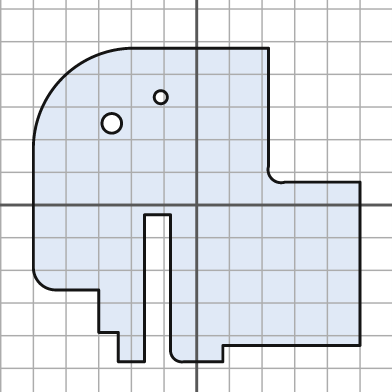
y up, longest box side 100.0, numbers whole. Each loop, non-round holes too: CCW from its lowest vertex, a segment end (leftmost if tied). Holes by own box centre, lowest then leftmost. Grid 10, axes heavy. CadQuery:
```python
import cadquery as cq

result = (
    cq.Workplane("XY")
    .moveTo(-24.0, -48.0)
    .lineTo(-16.0, -48.0)
    .lineTo(-16.0, -3.0)
    .lineTo(-8.0, -3.0)
    .lineTo(-8.0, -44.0)
    .threePointArc((-7.0, -47.0), (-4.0, -48.0))
    .lineTo(8.0, -48.0)
    .lineTo(8.0, -43.0)
    .lineTo(50.0, -43.0)
    .lineTo(50.0, 7.0)
    .lineTo(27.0, 7.0)
    .threePointArc((23.0, 8.0), (22.0, 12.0))
    .lineTo(22.0, 48.0)
    .lineTo(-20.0, 48.0)
    .threePointArc((-41.0, 39.0), (-50.0, 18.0))
    .lineTo(-50.0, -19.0)
    .threePointArc((-48.0, -24.0), (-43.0, -26.0))
    .lineTo(-30.0, -26.0)
    .lineTo(-30.0, -39.0)
    .lineTo(-24.0, -39.0)
    .close()
    .moveTo(-26.0, 25.0)
    .circle(3.0)
    .moveTo(-11.0, 33.0)
    .circle(2.0)
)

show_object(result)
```